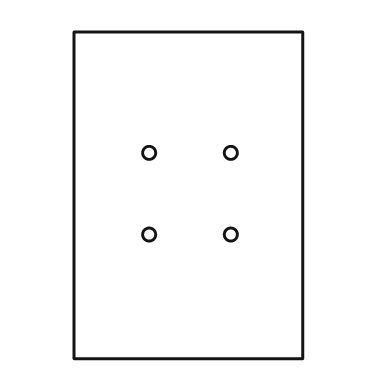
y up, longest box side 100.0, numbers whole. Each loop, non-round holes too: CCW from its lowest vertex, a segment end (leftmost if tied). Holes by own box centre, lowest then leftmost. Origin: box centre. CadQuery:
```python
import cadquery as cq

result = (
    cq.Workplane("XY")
    .moveTo(-35.0, -50.0)
    .lineTo(35.0, -50.0)
    .lineTo(35.0, 50.0)
    .lineTo(-35.0, 50.0)
    .close()
    .moveTo(-12.0, -12.0)
    .circle(2.0)
    .moveTo(13.0, -12.0)
    .circle(2.0)
    .moveTo(-12.0, 13.0)
    .circle(2.0)
    .moveTo(13.0, 13.0)
    .circle(2.0)
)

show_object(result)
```